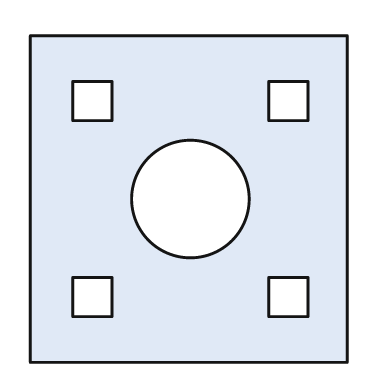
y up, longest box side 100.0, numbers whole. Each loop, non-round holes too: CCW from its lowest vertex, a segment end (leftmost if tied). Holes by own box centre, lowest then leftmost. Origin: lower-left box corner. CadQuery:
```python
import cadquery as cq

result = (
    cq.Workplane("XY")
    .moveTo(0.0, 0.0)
    .lineTo(97.0, 0.0)
    .lineTo(97.0, 100.0)
    .lineTo(0.0, 100.0)
    .close()
    .moveTo(13.0, 14.0)
    .lineTo(25.0, 14.0)
    .lineTo(25.0, 26.0)
    .lineTo(13.0, 26.0)
    .close()
    .moveTo(73.0, 14.0)
    .lineTo(85.0, 14.0)
    .lineTo(85.0, 26.0)
    .lineTo(73.0, 26.0)
    .close()
    .moveTo(49.0, 50.0)
    .circle(18.0)
    .moveTo(13.0, 74.0)
    .lineTo(25.0, 74.0)
    .lineTo(25.0, 86.0)
    .lineTo(13.0, 86.0)
    .close()
    .moveTo(73.0, 74.0)
    .lineTo(85.0, 74.0)
    .lineTo(85.0, 86.0)
    .lineTo(73.0, 86.0)
    .close()
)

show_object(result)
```